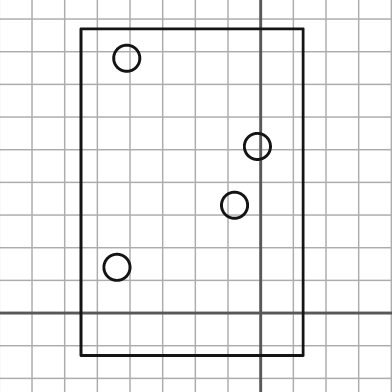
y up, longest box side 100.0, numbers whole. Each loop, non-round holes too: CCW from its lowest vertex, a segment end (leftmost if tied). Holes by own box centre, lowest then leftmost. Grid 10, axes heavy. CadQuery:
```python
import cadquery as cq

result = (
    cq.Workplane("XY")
    .moveTo(-55.0, -13.0)
    .lineTo(13.0, -13.0)
    .lineTo(13.0, 87.0)
    .lineTo(-55.0, 87.0)
    .close()
    .moveTo(-44.0, 14.0)
    .circle(4.0)
    .moveTo(-8.0, 33.0)
    .circle(4.0)
    .moveTo(-1.0, 51.0)
    .circle(4.0)
    .moveTo(-41.0, 78.0)
    .circle(4.0)
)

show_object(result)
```